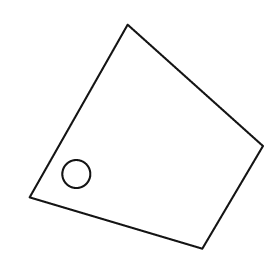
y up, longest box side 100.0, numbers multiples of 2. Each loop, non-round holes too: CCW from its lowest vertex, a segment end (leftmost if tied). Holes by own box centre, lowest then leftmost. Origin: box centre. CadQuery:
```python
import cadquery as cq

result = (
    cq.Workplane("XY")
    .moveTo(24.0, -48.0)
    .lineTo(50.0, -4.0)
    .lineTo(-8.0, 48.0)
    .lineTo(-50.0, -26.0)
    .close()
    .moveTo(-30.0, -16.0)
    .circle(6.0)
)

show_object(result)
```